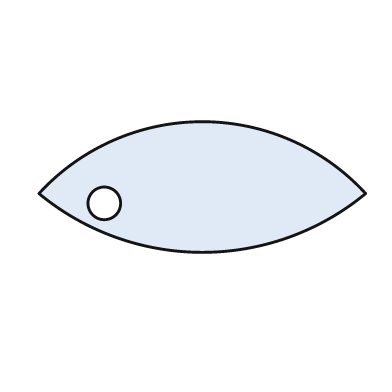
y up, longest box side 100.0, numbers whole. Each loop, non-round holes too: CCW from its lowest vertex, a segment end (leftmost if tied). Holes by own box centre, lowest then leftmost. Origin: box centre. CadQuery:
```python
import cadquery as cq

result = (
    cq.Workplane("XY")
    .moveTo(-50.0, -2.0)
    .threePointArc((0.0, -20.0), (50.0, -2.0))
    .threePointArc((0.0, 20.0), (-50.0, -2.0))
    .close()
    .moveTo(-30.0, -5.0)
    .circle(5.0)
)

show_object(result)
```